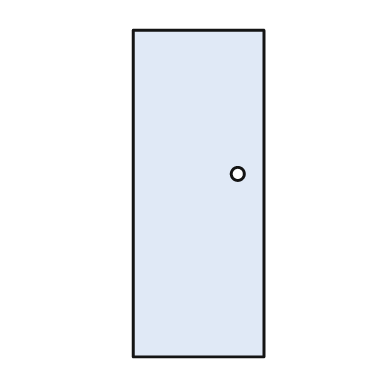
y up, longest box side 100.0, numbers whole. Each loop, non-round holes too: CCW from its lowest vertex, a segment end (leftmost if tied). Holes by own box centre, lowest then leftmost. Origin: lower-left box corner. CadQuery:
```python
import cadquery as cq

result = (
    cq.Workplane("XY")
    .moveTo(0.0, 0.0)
    .lineTo(40.0, 0.0)
    .lineTo(40.0, 100.0)
    .lineTo(0.0, 100.0)
    .close()
    .moveTo(32.0, 56.0)
    .circle(2.0)
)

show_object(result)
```